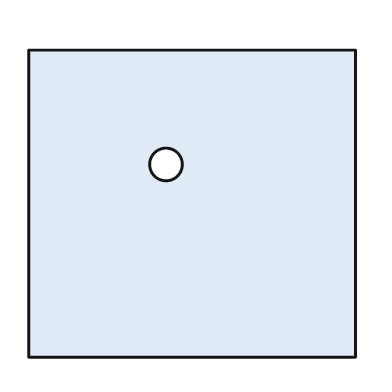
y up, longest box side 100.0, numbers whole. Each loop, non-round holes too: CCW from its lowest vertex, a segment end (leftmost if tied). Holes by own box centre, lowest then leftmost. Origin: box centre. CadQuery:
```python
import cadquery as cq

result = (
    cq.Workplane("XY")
    .moveTo(-50.0, -47.0)
    .lineTo(50.0, -47.0)
    .lineTo(50.0, 47.0)
    .lineTo(-50.0, 47.0)
    .close()
    .moveTo(-8.0, 12.0)
    .circle(5.0)
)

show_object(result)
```